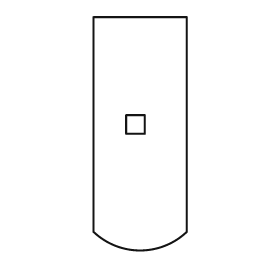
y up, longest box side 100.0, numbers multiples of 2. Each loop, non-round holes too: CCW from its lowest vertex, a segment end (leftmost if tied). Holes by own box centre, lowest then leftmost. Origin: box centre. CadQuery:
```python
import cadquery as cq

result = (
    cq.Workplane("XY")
    .moveTo(-20.0, -42.0)
    .threePointArc((0.0, -50.0), (20.0, -42.0))
    .lineTo(20.0, 50.0)
    .lineTo(-20.0, 50.0)
    .close()
    .moveTo(-6.0, 0.0)
    .lineTo(2.0, 0.0)
    .lineTo(2.0, 8.0)
    .lineTo(-6.0, 8.0)
    .close()
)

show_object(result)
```